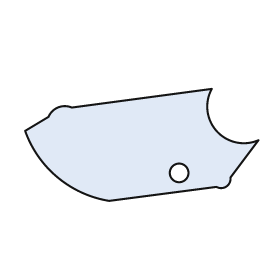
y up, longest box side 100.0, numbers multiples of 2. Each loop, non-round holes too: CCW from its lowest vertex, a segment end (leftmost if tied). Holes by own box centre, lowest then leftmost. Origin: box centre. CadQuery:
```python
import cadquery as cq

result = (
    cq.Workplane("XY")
    .moveTo(-14.0, -24.0)
    .lineTo(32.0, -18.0)
    .threePointArc((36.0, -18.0), (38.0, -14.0))
    .lineTo(50.0, 2.0)
    .threePointArc((32.0, 6.0), (30.0, 24.0))
    .lineTo(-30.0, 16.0)
    .threePointArc((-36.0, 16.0), (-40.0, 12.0))
    .lineTo(-50.0, 6.0)
    .threePointArc((-36.0, -14.0), (-14.0, -24.0))
    .close()
    .moveTo(16.0, -12.0)
    .circle(4.0)
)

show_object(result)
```